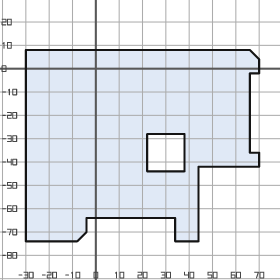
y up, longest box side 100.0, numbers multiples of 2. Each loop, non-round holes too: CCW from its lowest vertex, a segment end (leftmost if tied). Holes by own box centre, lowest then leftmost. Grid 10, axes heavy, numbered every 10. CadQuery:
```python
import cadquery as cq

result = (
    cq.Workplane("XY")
    .moveTo(-30.0, -74.0)
    .lineTo(-8.0, -74.0)
    .lineTo(-4.0, -70.0)
    .lineTo(-4.0, -64.0)
    .lineTo(34.0, -64.0)
    .lineTo(34.0, -74.0)
    .lineTo(44.0, -74.0)
    .lineTo(44.0, -42.0)
    .lineTo(70.0, -42.0)
    .lineTo(70.0, -36.0)
    .lineTo(66.0, -36.0)
    .lineTo(66.0, -2.0)
    .lineTo(70.0, -2.0)
    .lineTo(70.0, 4.0)
    .lineTo(66.0, 8.0)
    .lineTo(-30.0, 8.0)
    .close()
    .moveTo(22.0, -44.0)
    .lineTo(38.0, -44.0)
    .lineTo(38.0, -28.0)
    .lineTo(22.0, -28.0)
    .close()
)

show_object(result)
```